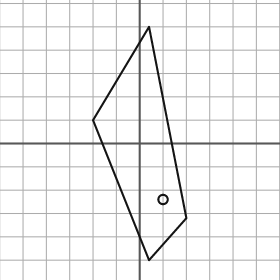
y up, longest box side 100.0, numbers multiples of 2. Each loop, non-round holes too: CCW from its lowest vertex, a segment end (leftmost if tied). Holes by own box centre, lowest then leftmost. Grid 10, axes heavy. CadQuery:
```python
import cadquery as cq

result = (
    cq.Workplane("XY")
    .moveTo(4.0, -50.0)
    .lineTo(20.0, -32.0)
    .lineTo(4.0, 50.0)
    .lineTo(-20.0, 10.0)
    .close()
    .moveTo(10.0, -24.0)
    .circle(2.0)
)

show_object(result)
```